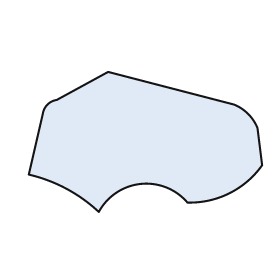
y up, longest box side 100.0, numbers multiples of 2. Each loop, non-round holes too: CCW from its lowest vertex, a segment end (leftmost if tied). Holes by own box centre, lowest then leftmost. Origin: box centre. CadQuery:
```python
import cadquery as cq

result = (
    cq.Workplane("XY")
    .moveTo(-20.0, -30.0)
    .threePointArc((-2.0, -18.0), (18.0, -26.0))
    .threePointArc((36.0, -22.0), (50.0, -10.0))
    .lineTo(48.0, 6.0)
    .threePointArc((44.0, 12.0), (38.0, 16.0))
    .lineTo(-16.0, 30.0)
    .lineTo(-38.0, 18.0)
    .threePointArc((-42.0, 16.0), (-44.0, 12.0))
    .lineTo(-50.0, -14.0)
    .threePointArc((-34.0, -20.0), (-20.0, -30.0))
    .close()
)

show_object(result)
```